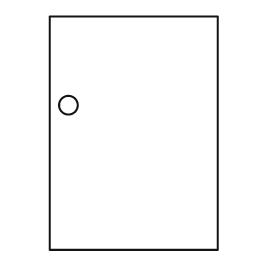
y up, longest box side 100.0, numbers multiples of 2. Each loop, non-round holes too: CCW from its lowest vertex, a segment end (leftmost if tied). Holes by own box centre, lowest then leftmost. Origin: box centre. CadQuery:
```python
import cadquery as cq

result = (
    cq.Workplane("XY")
    .moveTo(-36.0, -50.0)
    .lineTo(36.0, -50.0)
    .lineTo(36.0, 50.0)
    .lineTo(-36.0, 50.0)
    .close()
    .moveTo(-28.0, 12.0)
    .circle(4.0)
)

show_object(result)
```